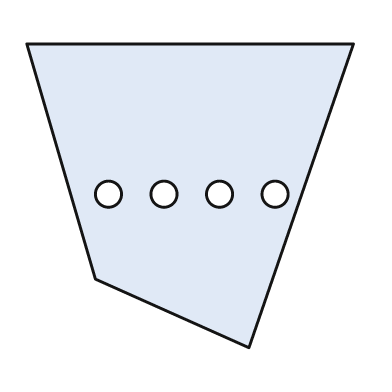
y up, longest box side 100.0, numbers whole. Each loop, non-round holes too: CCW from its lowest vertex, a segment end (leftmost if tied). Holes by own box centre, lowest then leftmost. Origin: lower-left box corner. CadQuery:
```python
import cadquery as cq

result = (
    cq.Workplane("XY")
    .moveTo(68.0, 0.0)
    .lineTo(100.0, 93.0)
    .lineTo(0.0, 93.0)
    .lineTo(21.0, 21.0)
    .close()
    .moveTo(25.0, 47.0)
    .circle(4.0)
    .moveTo(42.0, 47.0)
    .circle(4.0)
    .moveTo(59.0, 47.0)
    .circle(4.0)
    .moveTo(76.0, 47.0)
    .circle(4.0)
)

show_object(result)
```